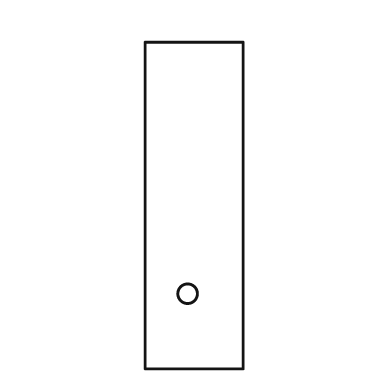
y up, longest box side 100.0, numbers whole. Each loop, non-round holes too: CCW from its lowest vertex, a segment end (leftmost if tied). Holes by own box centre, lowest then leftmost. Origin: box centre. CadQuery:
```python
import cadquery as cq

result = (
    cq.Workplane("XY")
    .moveTo(-15.0, -50.0)
    .lineTo(15.0, -50.0)
    .lineTo(15.0, 50.0)
    .lineTo(-15.0, 50.0)
    .close()
    .moveTo(-2.0, -27.0)
    .circle(3.0)
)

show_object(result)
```